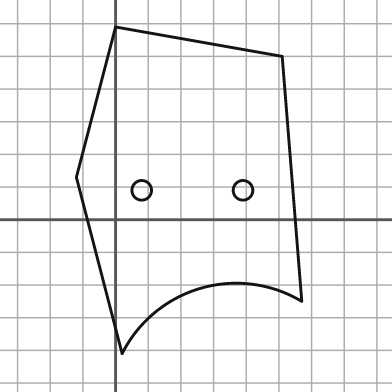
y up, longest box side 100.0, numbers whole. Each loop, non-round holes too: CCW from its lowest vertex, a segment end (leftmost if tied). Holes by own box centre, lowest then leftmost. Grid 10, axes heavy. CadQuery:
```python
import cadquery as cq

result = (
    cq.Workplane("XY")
    .moveTo(2.0, -41.0)
    .threePointArc((26.0, -21.0), (57.0, -25.0))
    .lineTo(51.0, 50.0)
    .lineTo(0.0, 59.0)
    .lineTo(-12.0, 13.0)
    .close()
    .moveTo(8.0, 9.0)
    .circle(3.0)
    .moveTo(39.0, 9.0)
    .circle(3.0)
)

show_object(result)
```